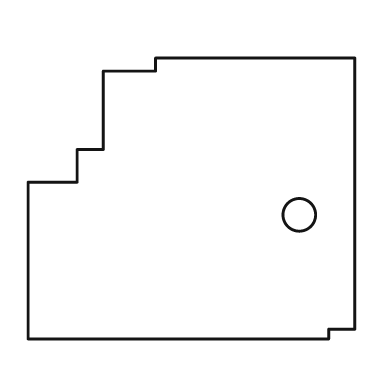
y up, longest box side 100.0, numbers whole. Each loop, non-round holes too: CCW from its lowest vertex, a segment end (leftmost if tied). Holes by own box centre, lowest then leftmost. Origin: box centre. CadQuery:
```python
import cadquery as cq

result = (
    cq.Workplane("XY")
    .moveTo(-50.0, -43.0)
    .lineTo(42.0, -43.0)
    .lineTo(42.0, -40.0)
    .lineTo(50.0, -40.0)
    .lineTo(50.0, 43.0)
    .lineTo(-11.0, 43.0)
    .lineTo(-11.0, 39.0)
    .lineTo(-27.0, 39.0)
    .lineTo(-27.0, 15.0)
    .lineTo(-35.0, 15.0)
    .lineTo(-35.0, 5.0)
    .lineTo(-50.0, 5.0)
    .close()
    .moveTo(33.0, -5.0)
    .circle(5.0)
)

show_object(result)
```